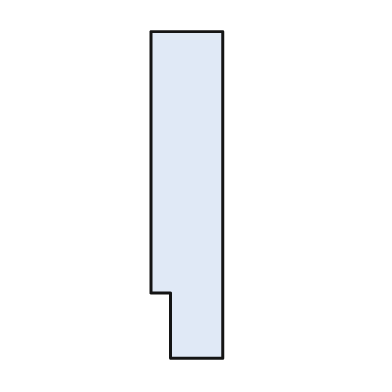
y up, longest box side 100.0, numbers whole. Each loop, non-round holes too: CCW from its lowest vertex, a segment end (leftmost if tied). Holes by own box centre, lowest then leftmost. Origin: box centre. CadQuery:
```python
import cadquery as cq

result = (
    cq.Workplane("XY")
    .moveTo(-5.0, -50.0)
    .lineTo(11.0, -50.0)
    .lineTo(11.0, 50.0)
    .lineTo(-11.0, 50.0)
    .lineTo(-11.0, -30.0)
    .lineTo(-5.0, -30.0)
    .close()
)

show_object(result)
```